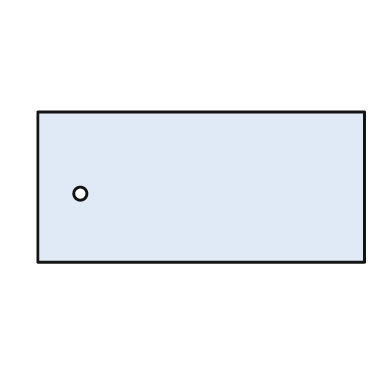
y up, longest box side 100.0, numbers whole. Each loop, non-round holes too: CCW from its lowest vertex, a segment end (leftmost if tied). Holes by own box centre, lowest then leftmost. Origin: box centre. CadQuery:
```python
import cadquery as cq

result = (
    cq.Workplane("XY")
    .moveTo(-50.0, -23.0)
    .lineTo(50.0, -23.0)
    .lineTo(50.0, 23.0)
    .lineTo(-50.0, 23.0)
    .close()
    .moveTo(-37.0, -2.0)
    .circle(2.0)
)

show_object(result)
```